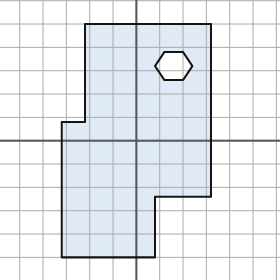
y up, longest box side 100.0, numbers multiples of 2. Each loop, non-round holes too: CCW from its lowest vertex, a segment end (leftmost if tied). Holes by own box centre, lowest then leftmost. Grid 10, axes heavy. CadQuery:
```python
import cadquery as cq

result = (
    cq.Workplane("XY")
    .moveTo(-32.0, -50.0)
    .lineTo(8.0, -50.0)
    .lineTo(8.0, -24.0)
    .lineTo(32.0, -24.0)
    .lineTo(32.0, 50.0)
    .lineTo(-22.0, 50.0)
    .lineTo(-22.0, 8.0)
    .lineTo(-32.0, 8.0)
    .close()
    .moveTo(12.0, 26.0)
    .lineTo(20.0, 26.0)
    .lineTo(24.0, 32.0)
    .lineTo(20.0, 38.0)
    .lineTo(12.0, 38.0)
    .lineTo(8.0, 32.0)
    .close()
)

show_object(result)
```